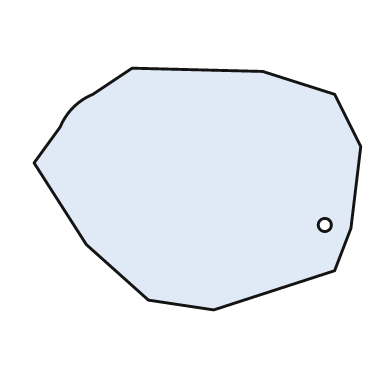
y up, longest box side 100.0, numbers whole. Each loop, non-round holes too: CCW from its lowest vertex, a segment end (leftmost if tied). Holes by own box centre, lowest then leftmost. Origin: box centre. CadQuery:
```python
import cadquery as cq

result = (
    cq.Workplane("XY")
    .moveTo(5.0, -37.0)
    .lineTo(42.0, -25.0)
    .lineTo(47.0, -12.0)
    .lineTo(50.0, 13.0)
    .lineTo(42.0, 29.0)
    .lineTo(20.0, 36.0)
    .lineTo(-20.0, 37.0)
    .lineTo(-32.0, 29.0)
    .threePointArc((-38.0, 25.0), (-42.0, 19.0))
    .lineTo(-50.0, 8.0)
    .lineTo(-34.0, -17.0)
    .lineTo(-15.0, -34.0)
    .close()
    .moveTo(39.0, -11.0)
    .circle(2.0)
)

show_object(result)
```